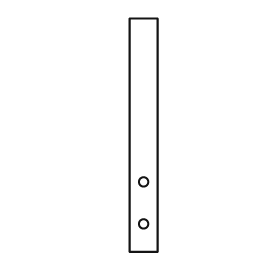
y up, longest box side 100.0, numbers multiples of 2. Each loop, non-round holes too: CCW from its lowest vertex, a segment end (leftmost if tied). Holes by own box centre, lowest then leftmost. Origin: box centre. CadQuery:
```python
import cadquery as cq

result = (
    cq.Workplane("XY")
    .moveTo(-6.0, -50.0)
    .lineTo(6.0, -50.0)
    .lineTo(6.0, 50.0)
    .lineTo(-6.0, 50.0)
    .close()
    .moveTo(0.0, -38.0)
    .circle(2.0)
    .moveTo(0.0, -20.0)
    .circle(2.0)
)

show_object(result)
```